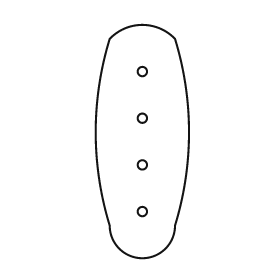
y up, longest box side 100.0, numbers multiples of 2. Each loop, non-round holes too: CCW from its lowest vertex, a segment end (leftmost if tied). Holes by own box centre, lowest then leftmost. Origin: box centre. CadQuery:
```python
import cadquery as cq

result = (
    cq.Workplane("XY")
    .moveTo(-14.0, -36.0)
    .threePointArc((0.0, -50.0), (14.0, -36.0))
    .threePointArc((20.0, 4.0), (14.0, 44.0))
    .threePointArc((0.0, 50.0), (-14.0, 44.0))
    .threePointArc((-20.0, 4.0), (-14.0, -36.0))
    .close()
    .moveTo(0.0, -30.0)
    .circle(2.0)
    .moveTo(0.0, -10.0)
    .circle(2.0)
    .moveTo(0.0, 10.0)
    .circle(2.0)
    .moveTo(0.0, 30.0)
    .circle(2.0)
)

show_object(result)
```